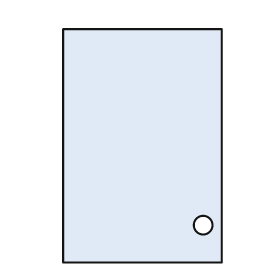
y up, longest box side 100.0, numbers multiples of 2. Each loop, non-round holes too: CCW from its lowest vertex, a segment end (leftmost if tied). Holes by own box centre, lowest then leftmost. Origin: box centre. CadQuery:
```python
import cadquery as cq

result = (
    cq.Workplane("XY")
    .moveTo(-34.0, -50.0)
    .lineTo(34.0, -50.0)
    .lineTo(34.0, 50.0)
    .lineTo(-34.0, 50.0)
    .close()
    .moveTo(26.0, -34.0)
    .circle(4.0)
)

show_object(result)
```